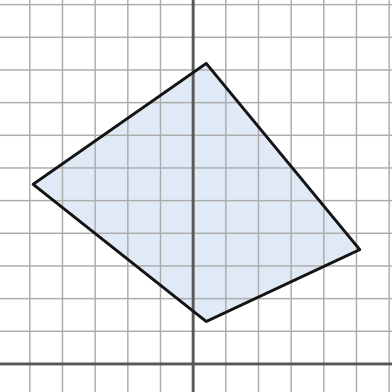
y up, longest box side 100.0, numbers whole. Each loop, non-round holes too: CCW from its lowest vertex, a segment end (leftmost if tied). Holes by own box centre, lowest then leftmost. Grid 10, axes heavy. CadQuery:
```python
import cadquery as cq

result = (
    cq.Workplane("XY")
    .moveTo(4.0, 13.0)
    .lineTo(51.0, 35.0)
    .lineTo(4.0, 92.0)
    .lineTo(-49.0, 55.0)
    .close()
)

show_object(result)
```